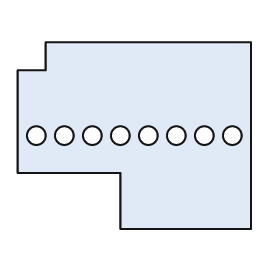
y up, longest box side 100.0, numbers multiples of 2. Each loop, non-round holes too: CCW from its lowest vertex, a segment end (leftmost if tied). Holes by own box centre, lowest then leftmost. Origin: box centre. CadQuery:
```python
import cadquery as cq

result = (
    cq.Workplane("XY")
    .moveTo(-6.0, -40.0)
    .lineTo(50.0, -40.0)
    .lineTo(50.0, 40.0)
    .lineTo(-38.0, 40.0)
    .lineTo(-38.0, 28.0)
    .lineTo(-50.0, 28.0)
    .lineTo(-50.0, -16.0)
    .lineTo(-6.0, -16.0)
    .close()
    .moveTo(-42.0, 0.0)
    .circle(4.0)
    .moveTo(-30.0, 0.0)
    .circle(4.0)
    .moveTo(-18.0, 0.0)
    .circle(4.0)
    .moveTo(-6.0, 0.0)
    .circle(4.0)
    .moveTo(6.0, 0.0)
    .circle(4.0)
    .moveTo(18.0, 0.0)
    .circle(4.0)
    .moveTo(30.0, 0.0)
    .circle(4.0)
    .moveTo(42.0, 0.0)
    .circle(4.0)
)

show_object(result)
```